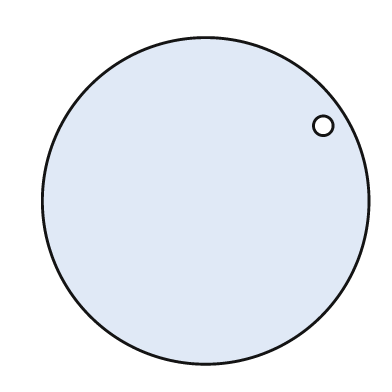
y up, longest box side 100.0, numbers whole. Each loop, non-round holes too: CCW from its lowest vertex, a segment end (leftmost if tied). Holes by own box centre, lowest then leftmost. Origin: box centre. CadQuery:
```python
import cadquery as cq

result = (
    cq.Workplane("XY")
    .moveTo(0.0, 0.0)
    .circle(50.0)
    .moveTo(36.0, 23.0)
    .circle(3.0)
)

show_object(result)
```